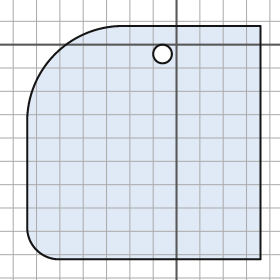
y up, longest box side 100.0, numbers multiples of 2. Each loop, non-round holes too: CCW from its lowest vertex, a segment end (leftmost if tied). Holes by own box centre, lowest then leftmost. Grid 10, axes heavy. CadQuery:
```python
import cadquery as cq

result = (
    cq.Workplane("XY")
    .moveTo(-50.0, -92.0)
    .lineTo(36.0, -92.0)
    .lineTo(36.0, 8.0)
    .lineTo(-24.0, 8.0)
    .threePointArc((-52.0, -4.0), (-64.0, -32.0))
    .lineTo(-64.0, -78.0)
    .threePointArc((-60.0, -88.0), (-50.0, -92.0))
    .close()
    .moveTo(-6.0, -4.0)
    .circle(4.0)
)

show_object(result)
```